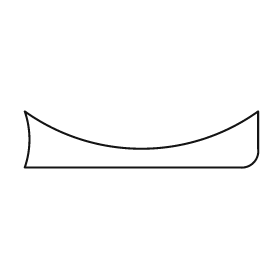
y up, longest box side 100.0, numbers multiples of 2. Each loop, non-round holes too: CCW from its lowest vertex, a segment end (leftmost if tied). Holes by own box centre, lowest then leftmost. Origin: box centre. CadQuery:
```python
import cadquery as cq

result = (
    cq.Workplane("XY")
    .moveTo(-50.0, -12.0)
    .lineTo(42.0, -12.0)
    .threePointArc((48.0, -10.0), (50.0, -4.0))
    .lineTo(50.0, 12.0)
    .threePointArc((0.0, -4.0), (-50.0, 12.0))
    .threePointArc((-48.0, 0.0), (-50.0, -12.0))
    .close()
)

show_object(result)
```